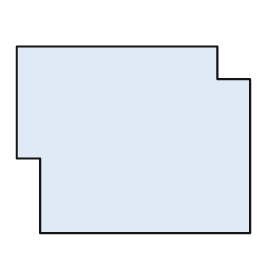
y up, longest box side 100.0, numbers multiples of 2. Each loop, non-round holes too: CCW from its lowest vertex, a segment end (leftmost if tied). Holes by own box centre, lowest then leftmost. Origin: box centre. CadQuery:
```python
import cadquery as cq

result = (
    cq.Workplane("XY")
    .moveTo(-40.0, -40.0)
    .lineTo(50.0, -40.0)
    .lineTo(50.0, 26.0)
    .lineTo(36.0, 26.0)
    .lineTo(36.0, 40.0)
    .lineTo(-50.0, 40.0)
    .lineTo(-50.0, -8.0)
    .lineTo(-40.0, -8.0)
    .close()
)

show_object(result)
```